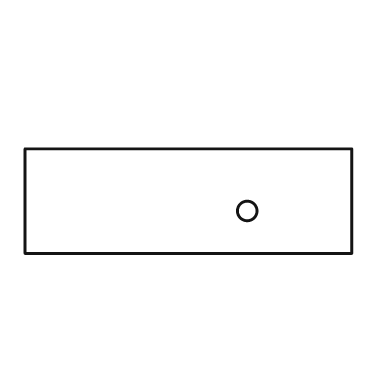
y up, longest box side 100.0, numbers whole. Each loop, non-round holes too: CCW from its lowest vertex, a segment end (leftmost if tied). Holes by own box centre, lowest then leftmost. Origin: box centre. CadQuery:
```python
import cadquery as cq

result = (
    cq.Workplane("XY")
    .moveTo(-50.0, -16.0)
    .lineTo(50.0, -16.0)
    .lineTo(50.0, 16.0)
    .lineTo(-50.0, 16.0)
    .close()
    .moveTo(18.0, -3.0)
    .circle(3.0)
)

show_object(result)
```